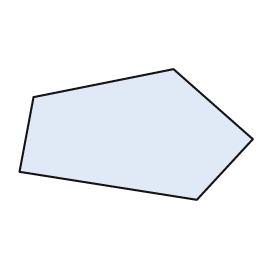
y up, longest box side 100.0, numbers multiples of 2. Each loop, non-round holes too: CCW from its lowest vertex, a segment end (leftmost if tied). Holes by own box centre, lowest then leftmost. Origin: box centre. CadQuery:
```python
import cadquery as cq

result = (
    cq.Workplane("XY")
    .moveTo(26.0, -28.0)
    .lineTo(50.0, -2.0)
    .lineTo(16.0, 28.0)
    .lineTo(-44.0, 16.0)
    .lineTo(-50.0, -16.0)
    .close()
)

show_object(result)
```